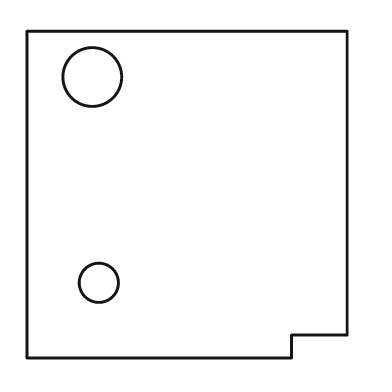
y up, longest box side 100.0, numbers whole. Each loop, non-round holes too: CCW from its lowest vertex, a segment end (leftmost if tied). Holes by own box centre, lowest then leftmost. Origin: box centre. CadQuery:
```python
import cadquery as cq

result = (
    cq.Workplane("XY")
    .moveTo(-49.0, -50.0)
    .lineTo(32.0, -50.0)
    .lineTo(32.0, -43.0)
    .lineTo(49.0, -43.0)
    .lineTo(49.0, 50.0)
    .lineTo(-49.0, 50.0)
    .close()
    .moveTo(-27.0, -27.0)
    .circle(6.0)
    .moveTo(-29.0, 36.0)
    .circle(9.0)
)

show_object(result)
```